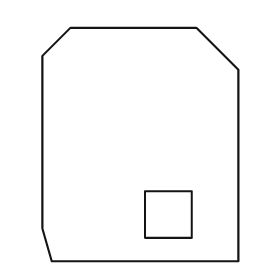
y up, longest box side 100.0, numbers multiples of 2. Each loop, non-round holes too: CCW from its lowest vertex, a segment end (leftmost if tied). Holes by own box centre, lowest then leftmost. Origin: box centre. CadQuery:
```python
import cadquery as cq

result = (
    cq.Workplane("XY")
    .moveTo(-38.0, -50.0)
    .lineTo(42.0, -50.0)
    .lineTo(42.0, 32.0)
    .lineTo(24.0, 50.0)
    .lineTo(-30.0, 50.0)
    .lineTo(-42.0, 38.0)
    .lineTo(-42.0, -36.0)
    .close()
    .moveTo(2.0, -40.0)
    .lineTo(22.0, -40.0)
    .lineTo(22.0, -20.0)
    .lineTo(2.0, -20.0)
    .close()
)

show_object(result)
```